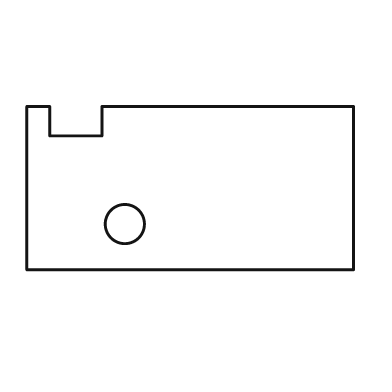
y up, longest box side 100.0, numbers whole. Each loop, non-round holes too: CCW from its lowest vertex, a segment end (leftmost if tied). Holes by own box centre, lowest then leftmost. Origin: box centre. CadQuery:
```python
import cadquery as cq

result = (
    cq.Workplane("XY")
    .moveTo(-50.0, -25.0)
    .lineTo(50.0, -25.0)
    .lineTo(50.0, 25.0)
    .lineTo(-27.0, 25.0)
    .lineTo(-27.0, 16.0)
    .lineTo(-43.0, 16.0)
    .lineTo(-43.0, 25.0)
    .lineTo(-50.0, 25.0)
    .close()
    .moveTo(-20.0, -11.0)
    .circle(6.0)
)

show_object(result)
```